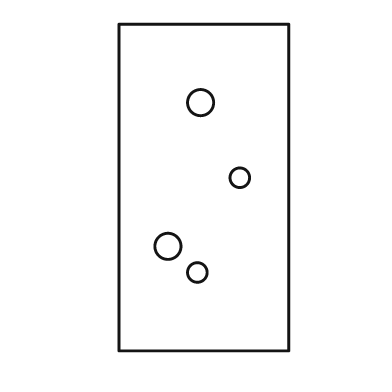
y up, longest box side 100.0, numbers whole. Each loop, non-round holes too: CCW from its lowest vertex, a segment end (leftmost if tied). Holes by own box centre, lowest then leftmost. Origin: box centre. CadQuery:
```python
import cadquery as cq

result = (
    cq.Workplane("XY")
    .moveTo(-26.0, -50.0)
    .lineTo(26.0, -50.0)
    .lineTo(26.0, 50.0)
    .lineTo(-26.0, 50.0)
    .close()
    .moveTo(-2.0, -26.0)
    .circle(3.0)
    .moveTo(-11.0, -18.0)
    .circle(4.0)
    .moveTo(11.0, 3.0)
    .circle(3.0)
    .moveTo(-1.0, 26.0)
    .circle(4.0)
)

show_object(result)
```